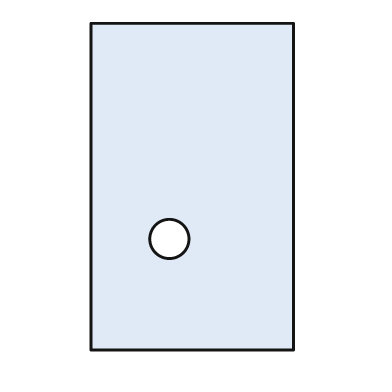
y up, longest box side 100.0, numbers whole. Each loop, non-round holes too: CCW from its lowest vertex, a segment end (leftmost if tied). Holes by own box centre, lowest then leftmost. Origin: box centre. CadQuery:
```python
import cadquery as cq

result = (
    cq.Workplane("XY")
    .moveTo(-31.0, -50.0)
    .lineTo(31.0, -50.0)
    .lineTo(31.0, 50.0)
    .lineTo(-31.0, 50.0)
    .close()
    .moveTo(-7.0, -16.0)
    .circle(6.0)
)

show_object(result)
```